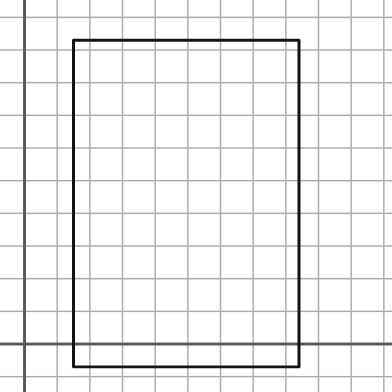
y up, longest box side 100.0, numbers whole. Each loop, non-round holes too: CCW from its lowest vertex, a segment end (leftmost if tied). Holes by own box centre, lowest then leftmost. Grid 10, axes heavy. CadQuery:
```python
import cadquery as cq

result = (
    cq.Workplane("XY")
    .moveTo(15.0, -7.0)
    .lineTo(84.0, -7.0)
    .lineTo(84.0, 93.0)
    .lineTo(15.0, 93.0)
    .close()
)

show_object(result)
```